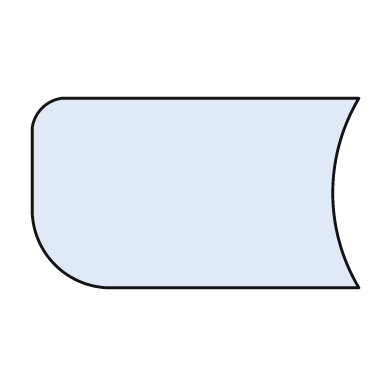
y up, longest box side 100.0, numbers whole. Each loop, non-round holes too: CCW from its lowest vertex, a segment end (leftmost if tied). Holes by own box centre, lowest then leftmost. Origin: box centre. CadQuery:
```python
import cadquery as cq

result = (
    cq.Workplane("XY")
    .moveTo(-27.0, -29.0)
    .lineTo(50.0, -29.0)
    .threePointArc((42.0, 0.0), (50.0, 29.0))
    .lineTo(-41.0, 29.0)
    .threePointArc((-47.0, 26.0), (-50.0, 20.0))
    .lineTo(-50.0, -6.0)
    .threePointArc((-43.0, -22.0), (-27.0, -29.0))
    .close()
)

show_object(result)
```